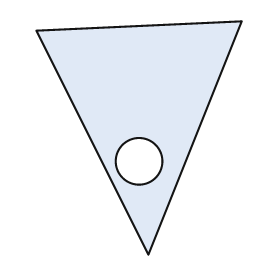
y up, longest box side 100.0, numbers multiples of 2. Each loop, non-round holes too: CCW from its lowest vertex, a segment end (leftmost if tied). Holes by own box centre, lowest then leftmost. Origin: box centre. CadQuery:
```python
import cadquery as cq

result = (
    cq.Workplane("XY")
    .moveTo(4.0, -50.0)
    .lineTo(44.0, 50.0)
    .lineTo(-44.0, 46.0)
    .close()
    .moveTo(0.0, -10.0)
    .circle(10.0)
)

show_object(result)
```